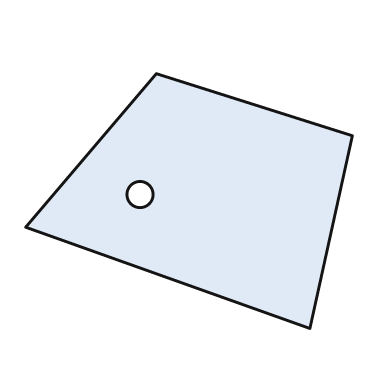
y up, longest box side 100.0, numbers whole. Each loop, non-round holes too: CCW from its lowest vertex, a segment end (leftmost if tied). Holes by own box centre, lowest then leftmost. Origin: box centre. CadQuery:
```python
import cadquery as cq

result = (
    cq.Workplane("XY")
    .moveTo(37.0, -39.0)
    .lineTo(50.0, 20.0)
    .lineTo(-10.0, 39.0)
    .lineTo(-50.0, -8.0)
    .close()
    .moveTo(-15.0, 2.0)
    .circle(4.0)
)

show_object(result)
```